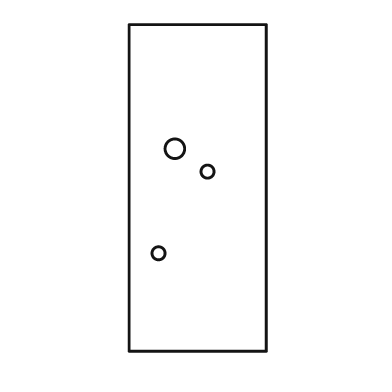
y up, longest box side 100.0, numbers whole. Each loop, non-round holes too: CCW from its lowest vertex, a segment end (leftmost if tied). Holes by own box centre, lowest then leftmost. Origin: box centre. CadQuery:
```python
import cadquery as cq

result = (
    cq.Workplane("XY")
    .moveTo(-21.0, -50.0)
    .lineTo(21.0, -50.0)
    .lineTo(21.0, 50.0)
    .lineTo(-21.0, 50.0)
    .close()
    .moveTo(-12.0, -20.0)
    .circle(2.0)
    .moveTo(3.0, 5.0)
    .circle(2.0)
    .moveTo(-7.0, 12.0)
    .circle(3.0)
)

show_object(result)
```